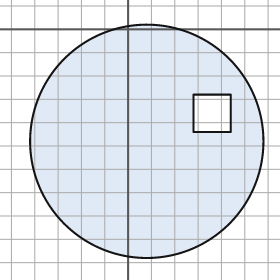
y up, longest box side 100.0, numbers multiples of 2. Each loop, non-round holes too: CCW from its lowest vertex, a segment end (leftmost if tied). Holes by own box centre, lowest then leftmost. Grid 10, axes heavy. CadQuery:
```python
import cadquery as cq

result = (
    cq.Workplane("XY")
    .moveTo(8.0, -48.0)
    .circle(50.0)
    .moveTo(28.0, -44.0)
    .lineTo(44.0, -44.0)
    .lineTo(44.0, -28.0)
    .lineTo(28.0, -28.0)
    .close()
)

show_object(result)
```